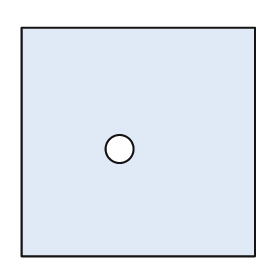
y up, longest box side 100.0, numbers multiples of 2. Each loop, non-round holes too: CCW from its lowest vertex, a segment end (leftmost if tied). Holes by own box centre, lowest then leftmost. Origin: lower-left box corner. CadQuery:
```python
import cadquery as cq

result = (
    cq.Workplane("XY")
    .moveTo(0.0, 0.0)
    .lineTo(100.0, 0.0)
    .lineTo(100.0, 98.0)
    .lineTo(0.0, 98.0)
    .close()
    .moveTo(42.0, 46.0)
    .circle(6.0)
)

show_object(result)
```